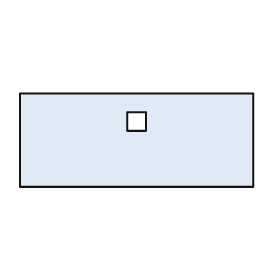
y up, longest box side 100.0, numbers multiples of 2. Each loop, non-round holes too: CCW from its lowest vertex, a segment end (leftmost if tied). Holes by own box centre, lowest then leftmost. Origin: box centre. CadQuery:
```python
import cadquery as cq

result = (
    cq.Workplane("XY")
    .moveTo(-50.0, -20.0)
    .lineTo(50.0, -20.0)
    .lineTo(50.0, 20.0)
    .lineTo(-50.0, 20.0)
    .close()
    .moveTo(-4.0, 4.0)
    .lineTo(4.0, 4.0)
    .lineTo(4.0, 12.0)
    .lineTo(-4.0, 12.0)
    .close()
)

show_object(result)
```